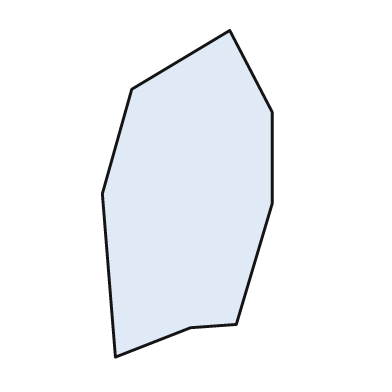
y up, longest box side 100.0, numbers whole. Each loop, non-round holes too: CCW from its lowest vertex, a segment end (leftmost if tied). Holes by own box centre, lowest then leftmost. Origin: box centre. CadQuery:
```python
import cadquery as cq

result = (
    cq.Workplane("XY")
    .moveTo(-22.0, -50.0)
    .lineTo(1.0, -41.0)
    .lineTo(15.0, -40.0)
    .lineTo(26.0, -3.0)
    .lineTo(26.0, 25.0)
    .lineTo(13.0, 50.0)
    .lineTo(-17.0, 32.0)
    .lineTo(-26.0, 0.0)
    .close()
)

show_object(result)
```